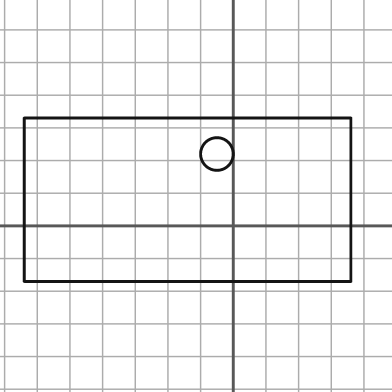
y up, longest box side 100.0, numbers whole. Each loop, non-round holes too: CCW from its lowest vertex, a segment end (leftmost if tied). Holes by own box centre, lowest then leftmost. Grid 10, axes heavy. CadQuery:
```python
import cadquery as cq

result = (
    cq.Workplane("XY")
    .moveTo(-64.0, -17.0)
    .lineTo(36.0, -17.0)
    .lineTo(36.0, 33.0)
    .lineTo(-64.0, 33.0)
    .close()
    .moveTo(-5.0, 22.0)
    .circle(5.0)
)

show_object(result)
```